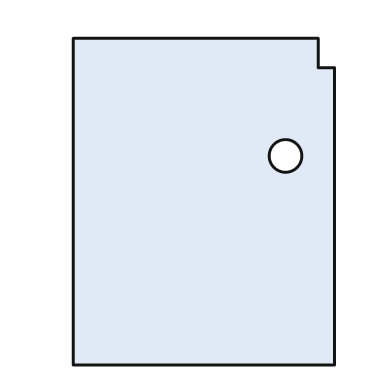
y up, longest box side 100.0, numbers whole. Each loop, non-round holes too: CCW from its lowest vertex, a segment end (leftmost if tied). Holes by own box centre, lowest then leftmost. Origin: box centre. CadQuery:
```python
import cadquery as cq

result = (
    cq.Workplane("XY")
    .moveTo(-40.0, -50.0)
    .lineTo(40.0, -50.0)
    .lineTo(40.0, 41.0)
    .lineTo(35.0, 41.0)
    .lineTo(35.0, 50.0)
    .lineTo(-40.0, 50.0)
    .close()
    .moveTo(25.0, 14.0)
    .circle(5.0)
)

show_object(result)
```